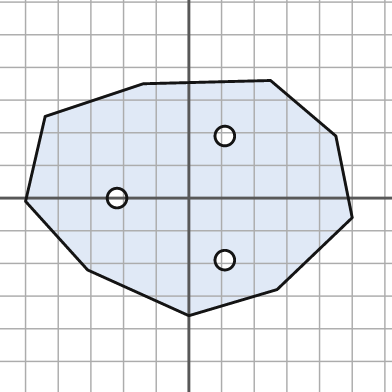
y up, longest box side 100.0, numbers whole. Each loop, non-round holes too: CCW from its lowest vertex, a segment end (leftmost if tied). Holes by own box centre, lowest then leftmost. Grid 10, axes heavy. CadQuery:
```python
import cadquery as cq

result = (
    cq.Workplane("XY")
    .moveTo(0.0, -36.0)
    .lineTo(27.0, -28.0)
    .lineTo(50.0, -6.0)
    .lineTo(45.0, 19.0)
    .lineTo(25.0, 36.0)
    .lineTo(-14.0, 35.0)
    .lineTo(-44.0, 25.0)
    .lineTo(-50.0, -1.0)
    .lineTo(-31.0, -22.0)
    .close()
    .moveTo(11.0, -19.0)
    .circle(3.0)
    .moveTo(-22.0, 0.0)
    .circle(3.0)
    .moveTo(11.0, 19.0)
    .circle(3.0)
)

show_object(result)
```